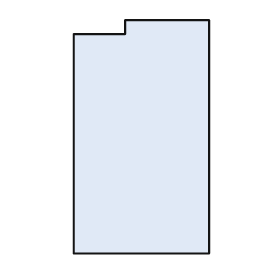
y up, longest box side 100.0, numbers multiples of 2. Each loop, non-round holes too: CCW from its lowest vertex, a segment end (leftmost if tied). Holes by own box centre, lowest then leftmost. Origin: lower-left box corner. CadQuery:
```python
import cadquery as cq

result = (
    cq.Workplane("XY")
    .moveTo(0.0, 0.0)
    .lineTo(58.0, 0.0)
    .lineTo(58.0, 100.0)
    .lineTo(22.0, 100.0)
    .lineTo(22.0, 94.0)
    .lineTo(0.0, 94.0)
    .close()
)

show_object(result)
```